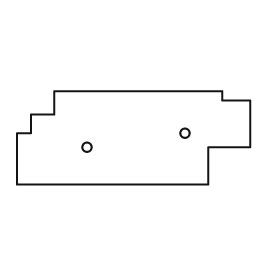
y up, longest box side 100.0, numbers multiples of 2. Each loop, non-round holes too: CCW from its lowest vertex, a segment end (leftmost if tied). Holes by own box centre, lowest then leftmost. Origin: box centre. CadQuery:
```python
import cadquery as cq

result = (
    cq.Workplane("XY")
    .moveTo(-50.0, -20.0)
    .lineTo(32.0, -20.0)
    .lineTo(32.0, -4.0)
    .lineTo(50.0, -4.0)
    .lineTo(50.0, 16.0)
    .lineTo(38.0, 16.0)
    .lineTo(38.0, 20.0)
    .lineTo(-34.0, 20.0)
    .lineTo(-34.0, 10.0)
    .lineTo(-44.0, 10.0)
    .lineTo(-44.0, 2.0)
    .lineTo(-50.0, 2.0)
    .close()
    .moveTo(-20.0, -4.0)
    .circle(2.0)
    .moveTo(22.0, 2.0)
    .circle(2.0)
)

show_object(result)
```